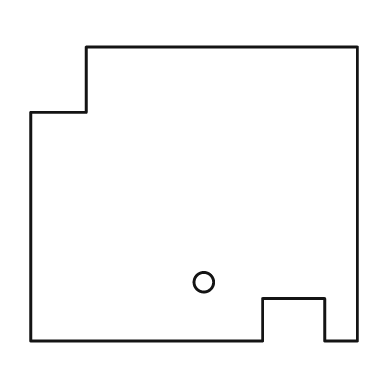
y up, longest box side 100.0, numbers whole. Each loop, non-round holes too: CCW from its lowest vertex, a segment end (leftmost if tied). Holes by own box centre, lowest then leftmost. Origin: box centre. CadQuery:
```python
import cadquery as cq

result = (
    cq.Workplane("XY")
    .moveTo(-50.0, -45.0)
    .lineTo(21.0, -45.0)
    .lineTo(21.0, -32.0)
    .lineTo(40.0, -32.0)
    .lineTo(40.0, -45.0)
    .lineTo(50.0, -45.0)
    .lineTo(50.0, 45.0)
    .lineTo(-33.0, 45.0)
    .lineTo(-33.0, 25.0)
    .lineTo(-50.0, 25.0)
    .close()
    .moveTo(3.0, -27.0)
    .circle(3.0)
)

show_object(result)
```